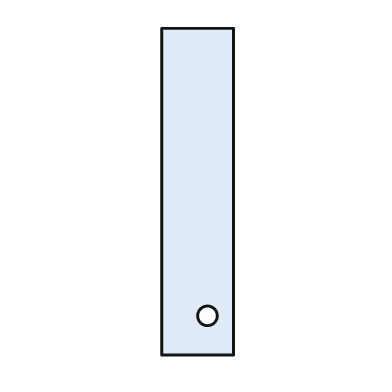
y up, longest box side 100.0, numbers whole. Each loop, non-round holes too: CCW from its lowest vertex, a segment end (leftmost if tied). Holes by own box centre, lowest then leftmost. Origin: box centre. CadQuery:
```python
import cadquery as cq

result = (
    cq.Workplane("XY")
    .moveTo(-11.0, -50.0)
    .lineTo(11.0, -50.0)
    .lineTo(11.0, 50.0)
    .lineTo(-11.0, 50.0)
    .close()
    .moveTo(3.0, -38.0)
    .circle(3.0)
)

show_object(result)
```